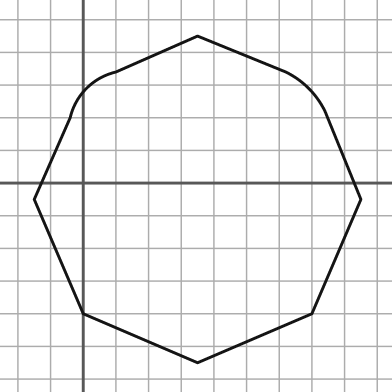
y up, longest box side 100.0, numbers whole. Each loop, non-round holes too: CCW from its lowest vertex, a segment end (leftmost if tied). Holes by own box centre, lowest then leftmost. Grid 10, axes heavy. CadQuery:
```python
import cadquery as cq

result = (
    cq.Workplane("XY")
    .moveTo(35.0, -55.0)
    .lineTo(70.0, -40.0)
    .lineTo(85.0, -5.0)
    .lineTo(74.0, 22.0)
    .threePointArc((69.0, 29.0), (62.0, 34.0))
    .lineTo(35.0, 45.0)
    .lineTo(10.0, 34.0)
    .threePointArc((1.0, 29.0), (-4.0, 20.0))
    .lineTo(-15.0, -5.0)
    .lineTo(0.0, -40.0)
    .close()
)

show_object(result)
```